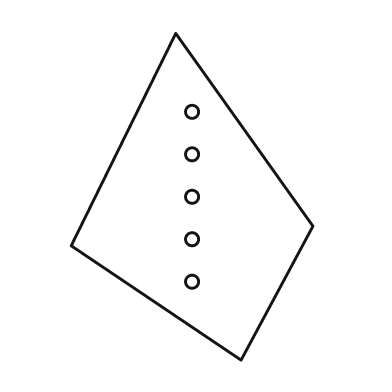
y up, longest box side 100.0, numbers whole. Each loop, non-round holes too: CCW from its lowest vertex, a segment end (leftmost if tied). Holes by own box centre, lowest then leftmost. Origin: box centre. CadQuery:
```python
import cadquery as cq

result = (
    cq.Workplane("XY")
    .moveTo(15.0, -50.0)
    .lineTo(37.0, -9.0)
    .lineTo(-5.0, 50.0)
    .lineTo(-37.0, -15.0)
    .close()
    .moveTo(0.0, -26.0)
    .circle(2.0)
    .moveTo(0.0, -13.0)
    .circle(2.0)
    .moveTo(0.0, 0.0)
    .circle(2.0)
    .moveTo(0.0, 13.0)
    .circle(2.0)
    .moveTo(0.0, 26.0)
    .circle(2.0)
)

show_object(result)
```